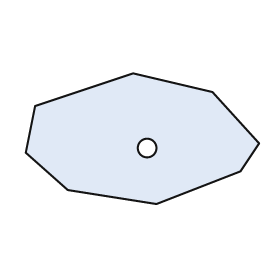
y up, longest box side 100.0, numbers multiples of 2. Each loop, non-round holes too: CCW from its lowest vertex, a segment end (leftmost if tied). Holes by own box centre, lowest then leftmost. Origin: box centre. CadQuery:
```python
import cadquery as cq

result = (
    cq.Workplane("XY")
    .moveTo(6.0, -28.0)
    .lineTo(42.0, -14.0)
    .lineTo(50.0, -2.0)
    .lineTo(30.0, 20.0)
    .lineTo(-4.0, 28.0)
    .lineTo(-46.0, 14.0)
    .lineTo(-50.0, -6.0)
    .lineTo(-32.0, -22.0)
    .close()
    .moveTo(2.0, -4.0)
    .circle(4.0)
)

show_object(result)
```